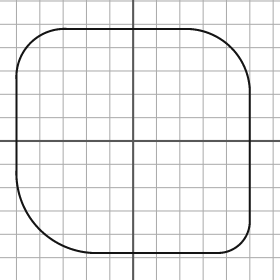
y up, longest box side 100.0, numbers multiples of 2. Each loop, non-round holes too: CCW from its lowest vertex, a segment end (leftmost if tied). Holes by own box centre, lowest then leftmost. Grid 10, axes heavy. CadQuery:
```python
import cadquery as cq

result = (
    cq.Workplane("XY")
    .moveTo(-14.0, -48.0)
    .lineTo(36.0, -48.0)
    .threePointArc((46.0, -44.0), (50.0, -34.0))
    .lineTo(50.0, 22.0)
    .threePointArc((42.0, 40.0), (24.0, 48.0))
    .lineTo(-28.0, 48.0)
    .threePointArc((-44.0, 42.0), (-50.0, 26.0))
    .lineTo(-50.0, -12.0)
    .threePointArc((-40.0, -38.0), (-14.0, -48.0))
    .close()
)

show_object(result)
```